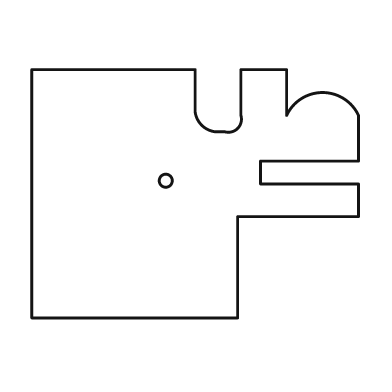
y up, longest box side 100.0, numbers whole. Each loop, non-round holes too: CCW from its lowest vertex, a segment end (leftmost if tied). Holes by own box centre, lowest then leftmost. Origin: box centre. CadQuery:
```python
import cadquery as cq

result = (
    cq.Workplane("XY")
    .moveTo(-50.0, -38.0)
    .lineTo(13.0, -38.0)
    .lineTo(13.0, -7.0)
    .lineTo(50.0, -7.0)
    .lineTo(50.0, 3.0)
    .lineTo(20.0, 3.0)
    .lineTo(20.0, 10.0)
    .lineTo(50.0, 10.0)
    .lineTo(50.0, 24.0)
    .threePointArc((39.0, 31.0), (28.0, 24.0))
    .lineTo(28.0, 38.0)
    .lineTo(14.0, 38.0)
    .lineTo(14.0, 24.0)
    .threePointArc((13.0, 20.0), (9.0, 19.0))
    .lineTo(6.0, 19.0)
    .threePointArc((2.0, 21.0), (0.0, 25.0))
    .lineTo(0.0, 38.0)
    .lineTo(-50.0, 38.0)
    .close()
    .moveTo(-9.0, 4.0)
    .circle(2.0)
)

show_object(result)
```